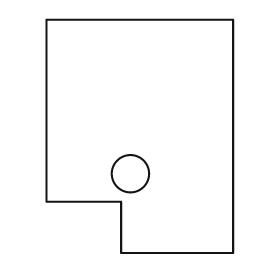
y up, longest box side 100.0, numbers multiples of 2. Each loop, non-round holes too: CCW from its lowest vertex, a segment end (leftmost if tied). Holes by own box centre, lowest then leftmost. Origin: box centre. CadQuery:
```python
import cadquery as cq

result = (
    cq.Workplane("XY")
    .moveTo(-8.0, -50.0)
    .lineTo(40.0, -50.0)
    .lineTo(40.0, 50.0)
    .lineTo(-40.0, 50.0)
    .lineTo(-40.0, -28.0)
    .lineTo(-8.0, -28.0)
    .close()
    .moveTo(-4.0, -16.0)
    .circle(8.0)
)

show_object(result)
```